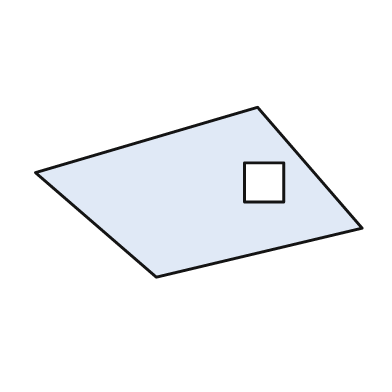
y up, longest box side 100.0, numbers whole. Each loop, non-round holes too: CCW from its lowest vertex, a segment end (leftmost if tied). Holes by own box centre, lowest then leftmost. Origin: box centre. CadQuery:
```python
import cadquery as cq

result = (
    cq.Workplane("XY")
    .moveTo(-13.0, -26.0)
    .lineTo(50.0, -11.0)
    .lineTo(18.0, 26.0)
    .lineTo(-50.0, 6.0)
    .close()
    .moveTo(14.0, -3.0)
    .lineTo(26.0, -3.0)
    .lineTo(26.0, 9.0)
    .lineTo(14.0, 9.0)
    .close()
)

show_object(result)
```